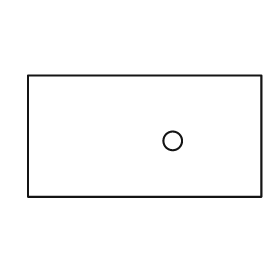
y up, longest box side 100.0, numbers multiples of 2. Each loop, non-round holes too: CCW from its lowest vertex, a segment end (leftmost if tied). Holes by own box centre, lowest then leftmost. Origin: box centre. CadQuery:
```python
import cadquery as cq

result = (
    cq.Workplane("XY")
    .moveTo(-50.0, -26.0)
    .lineTo(50.0, -26.0)
    .lineTo(50.0, 26.0)
    .lineTo(-50.0, 26.0)
    .close()
    .moveTo(12.0, -2.0)
    .circle(4.0)
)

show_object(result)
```